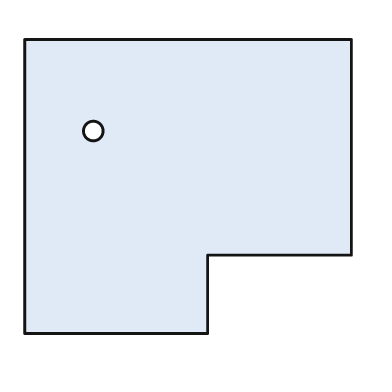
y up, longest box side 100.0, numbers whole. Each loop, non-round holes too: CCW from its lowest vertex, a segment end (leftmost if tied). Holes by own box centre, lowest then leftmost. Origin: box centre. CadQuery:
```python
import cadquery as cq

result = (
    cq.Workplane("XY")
    .moveTo(-50.0, -45.0)
    .lineTo(6.0, -45.0)
    .lineTo(6.0, -21.0)
    .lineTo(50.0, -21.0)
    .lineTo(50.0, 45.0)
    .lineTo(-50.0, 45.0)
    .close()
    .moveTo(-29.0, 17.0)
    .circle(3.0)
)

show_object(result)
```